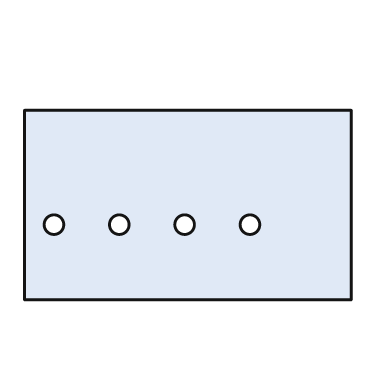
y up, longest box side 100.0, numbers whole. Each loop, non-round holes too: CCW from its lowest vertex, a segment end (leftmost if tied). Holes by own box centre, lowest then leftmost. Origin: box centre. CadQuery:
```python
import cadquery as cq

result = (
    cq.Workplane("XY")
    .moveTo(-50.0, -29.0)
    .lineTo(50.0, -29.0)
    .lineTo(50.0, 29.0)
    .lineTo(-50.0, 29.0)
    .close()
    .moveTo(-41.0, -6.0)
    .circle(3.0)
    .moveTo(-21.0, -6.0)
    .circle(3.0)
    .moveTo(-1.0, -6.0)
    .circle(3.0)
    .moveTo(19.0, -6.0)
    .circle(3.0)
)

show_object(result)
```